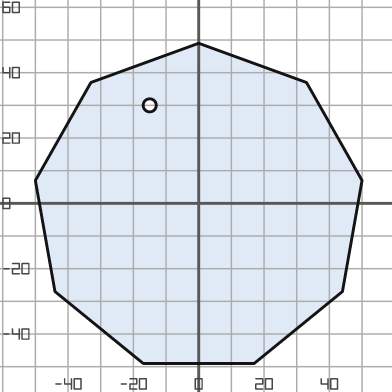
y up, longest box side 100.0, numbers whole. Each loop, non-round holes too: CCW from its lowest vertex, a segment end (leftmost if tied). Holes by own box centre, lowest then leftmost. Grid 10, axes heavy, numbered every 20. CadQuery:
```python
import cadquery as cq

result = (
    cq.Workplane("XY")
    .moveTo(-17.0, -49.0)
    .lineTo(17.0, -49.0)
    .lineTo(44.0, -27.0)
    .lineTo(50.0, 7.0)
    .lineTo(33.0, 37.0)
    .lineTo(0.0, 49.0)
    .lineTo(-33.0, 37.0)
    .lineTo(-50.0, 7.0)
    .lineTo(-44.0, -27.0)
    .close()
    .moveTo(-15.0, 30.0)
    .circle(2.0)
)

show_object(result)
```